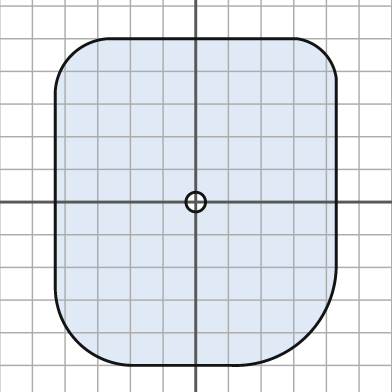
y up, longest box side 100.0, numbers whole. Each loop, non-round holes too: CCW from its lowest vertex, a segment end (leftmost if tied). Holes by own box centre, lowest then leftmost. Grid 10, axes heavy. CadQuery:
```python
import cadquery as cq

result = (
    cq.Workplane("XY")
    .moveTo(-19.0, -50.0)
    .lineTo(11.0, -50.0)
    .threePointArc((34.0, -41.0), (43.0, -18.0))
    .lineTo(43.0, 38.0)
    .threePointArc((39.0, 46.0), (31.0, 50.0))
    .lineTo(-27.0, 50.0)
    .threePointArc((-38.0, 45.0), (-43.0, 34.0))
    .lineTo(-43.0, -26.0)
    .threePointArc((-36.0, -43.0), (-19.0, -50.0))
    .close()
    .moveTo(0.0, 0.0)
    .circle(3.0)
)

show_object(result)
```